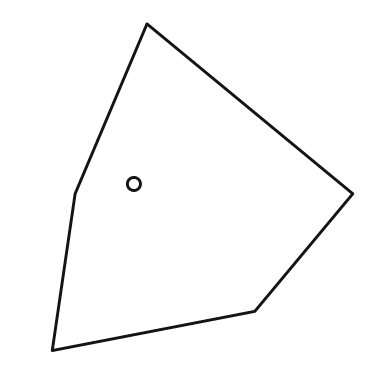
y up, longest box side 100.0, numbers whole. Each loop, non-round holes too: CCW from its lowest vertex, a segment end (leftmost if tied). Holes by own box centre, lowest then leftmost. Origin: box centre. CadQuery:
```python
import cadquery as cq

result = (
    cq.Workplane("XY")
    .moveTo(-46.0, -50.0)
    .lineTo(16.0, -38.0)
    .lineTo(46.0, -2.0)
    .lineTo(-17.0, 50.0)
    .lineTo(-39.0, -2.0)
    .close()
    .moveTo(-21.0, 1.0)
    .circle(2.0)
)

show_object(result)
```